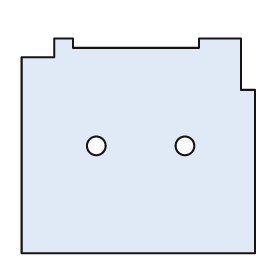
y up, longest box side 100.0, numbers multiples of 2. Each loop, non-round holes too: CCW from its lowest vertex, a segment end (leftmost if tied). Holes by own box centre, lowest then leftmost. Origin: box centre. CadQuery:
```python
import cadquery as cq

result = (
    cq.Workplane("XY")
    .moveTo(-50.0, -46.0)
    .lineTo(50.0, -46.0)
    .lineTo(50.0, 24.0)
    .lineTo(44.0, 24.0)
    .lineTo(44.0, 46.0)
    .lineTo(26.0, 46.0)
    .lineTo(26.0, 42.0)
    .lineTo(-28.0, 42.0)
    .lineTo(-28.0, 46.0)
    .lineTo(-36.0, 46.0)
    .lineTo(-36.0, 38.0)
    .lineTo(-50.0, 38.0)
    .close()
    .moveTo(-18.0, 0.0)
    .circle(4.0)
    .moveTo(20.0, 0.0)
    .circle(4.0)
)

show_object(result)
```